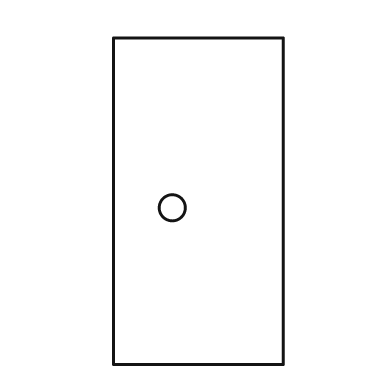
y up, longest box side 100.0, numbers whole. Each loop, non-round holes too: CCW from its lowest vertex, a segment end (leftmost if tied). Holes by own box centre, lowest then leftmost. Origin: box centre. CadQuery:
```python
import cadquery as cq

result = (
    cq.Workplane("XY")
    .moveTo(-26.0, -50.0)
    .lineTo(26.0, -50.0)
    .lineTo(26.0, 50.0)
    .lineTo(-26.0, 50.0)
    .close()
    .moveTo(-8.0, -2.0)
    .circle(4.0)
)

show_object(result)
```